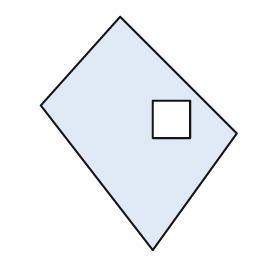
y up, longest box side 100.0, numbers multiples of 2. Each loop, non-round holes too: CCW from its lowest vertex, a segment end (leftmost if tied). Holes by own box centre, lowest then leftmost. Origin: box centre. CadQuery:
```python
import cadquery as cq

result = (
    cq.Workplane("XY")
    .moveTo(6.0, -50.0)
    .lineTo(42.0, 0.0)
    .lineTo(-8.0, 50.0)
    .lineTo(-42.0, 12.0)
    .close()
    .moveTo(6.0, -2.0)
    .lineTo(22.0, -2.0)
    .lineTo(22.0, 14.0)
    .lineTo(6.0, 14.0)
    .close()
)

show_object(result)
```